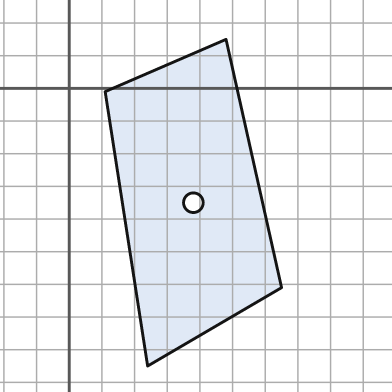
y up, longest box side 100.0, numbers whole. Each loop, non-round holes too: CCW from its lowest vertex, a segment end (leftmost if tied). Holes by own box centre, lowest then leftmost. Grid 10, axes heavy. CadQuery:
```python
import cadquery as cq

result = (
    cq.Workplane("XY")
    .moveTo(24.0, -85.0)
    .lineTo(65.0, -61.0)
    .lineTo(48.0, 15.0)
    .lineTo(11.0, -1.0)
    .close()
    .moveTo(38.0, -35.0)
    .circle(3.0)
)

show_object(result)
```